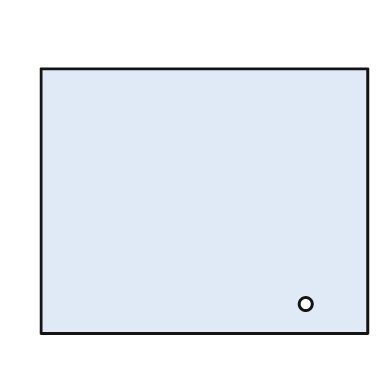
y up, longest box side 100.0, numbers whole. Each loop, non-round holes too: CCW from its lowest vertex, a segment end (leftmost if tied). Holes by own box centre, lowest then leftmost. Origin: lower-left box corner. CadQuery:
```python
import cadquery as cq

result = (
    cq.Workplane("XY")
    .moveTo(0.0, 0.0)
    .lineTo(100.0, 0.0)
    .lineTo(100.0, 81.0)
    .lineTo(0.0, 81.0)
    .close()
    .moveTo(81.0, 9.0)
    .circle(2.0)
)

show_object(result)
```